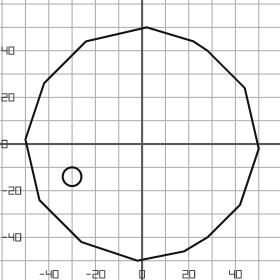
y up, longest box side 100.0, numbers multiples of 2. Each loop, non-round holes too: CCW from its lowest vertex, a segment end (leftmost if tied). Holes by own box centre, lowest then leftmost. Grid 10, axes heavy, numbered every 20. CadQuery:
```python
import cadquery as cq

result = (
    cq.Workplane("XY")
    .moveTo(-2.0, -50.0)
    .lineTo(18.0, -46.0)
    .lineTo(28.0, -40.0)
    .lineTo(42.0, -26.0)
    .lineTo(50.0, -2.0)
    .lineTo(44.0, 24.0)
    .lineTo(28.0, 40.0)
    .lineTo(22.0, 44.0)
    .lineTo(2.0, 50.0)
    .lineTo(-24.0, 44.0)
    .lineTo(-42.0, 26.0)
    .lineTo(-50.0, 2.0)
    .lineTo(-44.0, -24.0)
    .lineTo(-26.0, -42.0)
    .close()
    .moveTo(-30.0, -14.0)
    .circle(4.0)
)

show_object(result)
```